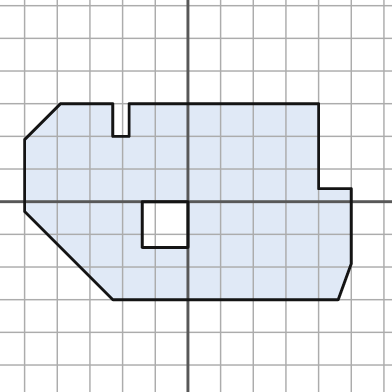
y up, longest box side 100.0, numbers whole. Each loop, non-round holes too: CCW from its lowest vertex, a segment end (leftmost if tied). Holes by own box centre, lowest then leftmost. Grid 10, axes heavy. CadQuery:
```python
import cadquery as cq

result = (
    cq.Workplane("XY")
    .moveTo(-23.0, -30.0)
    .lineTo(46.0, -30.0)
    .lineTo(50.0, -19.0)
    .lineTo(50.0, 4.0)
    .lineTo(40.0, 4.0)
    .lineTo(40.0, 30.0)
    .lineTo(-18.0, 30.0)
    .lineTo(-18.0, 20.0)
    .lineTo(-23.0, 20.0)
    .lineTo(-23.0, 30.0)
    .lineTo(-39.0, 30.0)
    .lineTo(-50.0, 19.0)
    .lineTo(-50.0, -3.0)
    .close()
    .moveTo(-14.0, -14.0)
    .lineTo(0.0, -14.0)
    .lineTo(0.0, 0.0)
    .lineTo(-14.0, 0.0)
    .close()
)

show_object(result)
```